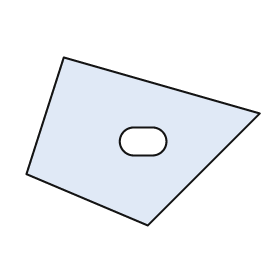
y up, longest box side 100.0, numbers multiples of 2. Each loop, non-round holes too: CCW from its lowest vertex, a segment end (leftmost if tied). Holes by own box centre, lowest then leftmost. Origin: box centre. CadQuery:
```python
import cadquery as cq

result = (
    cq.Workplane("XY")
    .moveTo(2.0, -36.0)
    .lineTo(50.0, 12.0)
    .lineTo(-34.0, 36.0)
    .lineTo(-50.0, -14.0)
    .close()
    .moveTo(-4.0, -6.0)
    .lineTo(4.0, -6.0)
    .threePointArc((10.0, 0.0), (4.0, 6.0))
    .lineTo(-4.0, 6.0)
    .threePointArc((-10.0, 0.0), (-4.0, -6.0))
    .close()
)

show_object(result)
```